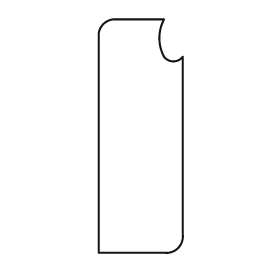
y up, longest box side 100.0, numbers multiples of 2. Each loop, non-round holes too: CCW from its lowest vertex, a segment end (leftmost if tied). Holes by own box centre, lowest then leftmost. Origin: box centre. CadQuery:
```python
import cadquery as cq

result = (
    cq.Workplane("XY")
    .moveTo(-18.0, -50.0)
    .lineTo(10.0, -50.0)
    .threePointArc((16.0, -48.0), (18.0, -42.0))
    .lineTo(18.0, 34.0)
    .threePointArc((14.0, 32.0), (10.0, 34.0))
    .threePointArc((8.0, 42.0), (10.0, 50.0))
    .lineTo(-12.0, 50.0)
    .threePointArc((-16.0, 48.0), (-18.0, 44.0))
    .close()
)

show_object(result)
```